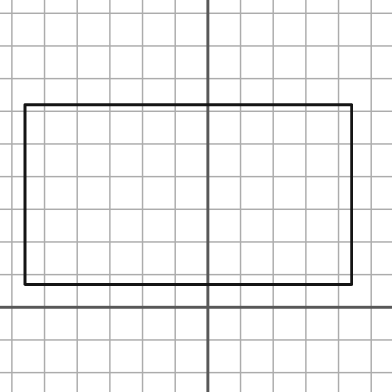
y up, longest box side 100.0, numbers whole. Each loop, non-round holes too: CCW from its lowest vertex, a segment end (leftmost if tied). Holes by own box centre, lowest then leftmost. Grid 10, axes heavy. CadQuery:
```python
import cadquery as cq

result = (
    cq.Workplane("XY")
    .moveTo(-56.0, 7.0)
    .lineTo(44.0, 7.0)
    .lineTo(44.0, 62.0)
    .lineTo(-56.0, 62.0)
    .close()
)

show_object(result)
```